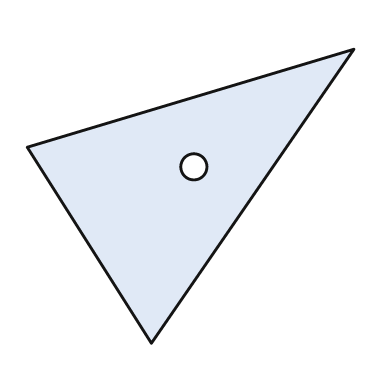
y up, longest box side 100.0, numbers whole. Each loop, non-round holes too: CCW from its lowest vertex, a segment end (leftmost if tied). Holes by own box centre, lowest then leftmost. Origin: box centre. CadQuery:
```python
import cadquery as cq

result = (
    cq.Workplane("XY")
    .moveTo(-12.0, -45.0)
    .lineTo(50.0, 45.0)
    .lineTo(-50.0, 15.0)
    .close()
    .moveTo(1.0, 9.0)
    .circle(4.0)
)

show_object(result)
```